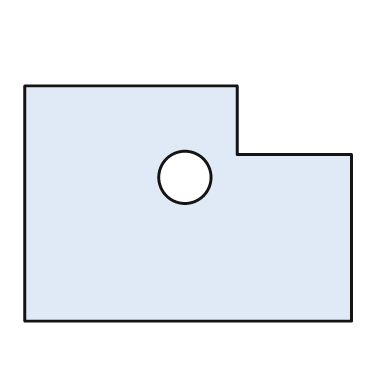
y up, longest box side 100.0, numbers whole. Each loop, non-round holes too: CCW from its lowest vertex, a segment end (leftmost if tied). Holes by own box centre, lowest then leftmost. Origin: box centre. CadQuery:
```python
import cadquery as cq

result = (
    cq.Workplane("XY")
    .moveTo(-50.0, -36.0)
    .lineTo(50.0, -36.0)
    .lineTo(50.0, 15.0)
    .lineTo(15.0, 15.0)
    .lineTo(15.0, 36.0)
    .lineTo(-50.0, 36.0)
    .close()
    .moveTo(-1.0, 8.0)
    .circle(8.0)
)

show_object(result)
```